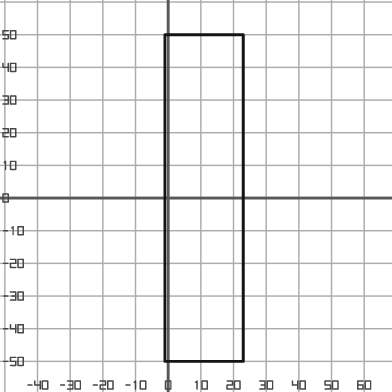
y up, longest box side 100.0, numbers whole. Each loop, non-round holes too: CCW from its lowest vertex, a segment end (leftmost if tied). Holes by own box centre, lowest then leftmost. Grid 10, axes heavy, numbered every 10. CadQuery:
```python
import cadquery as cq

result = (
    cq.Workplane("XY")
    .moveTo(-1.0, -50.0)
    .lineTo(23.0, -50.0)
    .lineTo(23.0, 50.0)
    .lineTo(-1.0, 50.0)
    .close()
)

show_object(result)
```